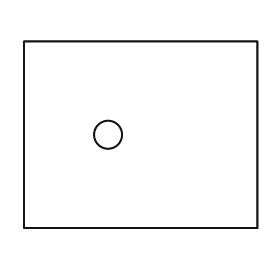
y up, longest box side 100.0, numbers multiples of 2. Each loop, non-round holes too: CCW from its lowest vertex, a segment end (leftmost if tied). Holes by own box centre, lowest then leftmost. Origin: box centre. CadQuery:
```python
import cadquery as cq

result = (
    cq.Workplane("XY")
    .moveTo(-50.0, -40.0)
    .lineTo(50.0, -40.0)
    .lineTo(50.0, 40.0)
    .lineTo(-50.0, 40.0)
    .close()
    .moveTo(-14.0, 0.0)
    .circle(6.0)
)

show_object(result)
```